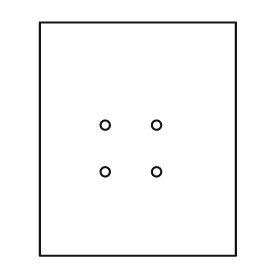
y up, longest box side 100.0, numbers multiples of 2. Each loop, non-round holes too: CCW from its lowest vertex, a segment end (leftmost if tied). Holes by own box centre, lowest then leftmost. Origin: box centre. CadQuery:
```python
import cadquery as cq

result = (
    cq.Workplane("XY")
    .moveTo(-42.0, -50.0)
    .lineTo(42.0, -50.0)
    .lineTo(42.0, 50.0)
    .lineTo(-42.0, 50.0)
    .close()
    .moveTo(-14.0, -14.0)
    .circle(2.0)
    .moveTo(8.0, -14.0)
    .circle(2.0)
    .moveTo(-14.0, 6.0)
    .circle(2.0)
    .moveTo(8.0, 6.0)
    .circle(2.0)
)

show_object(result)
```